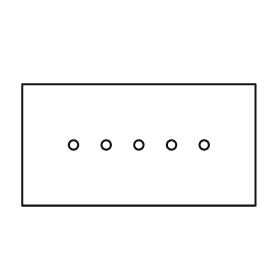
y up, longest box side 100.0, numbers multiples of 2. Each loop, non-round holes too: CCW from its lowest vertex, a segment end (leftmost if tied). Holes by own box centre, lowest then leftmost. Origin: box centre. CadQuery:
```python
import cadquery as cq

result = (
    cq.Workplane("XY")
    .moveTo(-50.0, -26.0)
    .lineTo(50.0, -26.0)
    .lineTo(50.0, 26.0)
    .lineTo(-50.0, 26.0)
    .close()
    .moveTo(-28.0, 0.0)
    .circle(2.0)
    .moveTo(-14.0, 0.0)
    .circle(2.0)
    .moveTo(0.0, 0.0)
    .circle(2.0)
    .moveTo(14.0, 0.0)
    .circle(2.0)
    .moveTo(28.0, 0.0)
    .circle(2.0)
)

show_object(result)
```